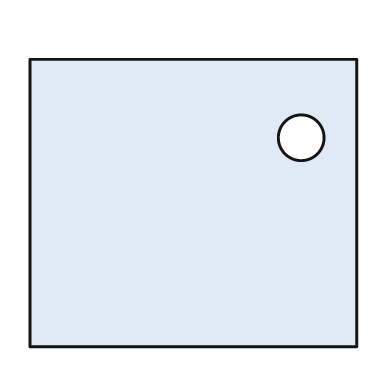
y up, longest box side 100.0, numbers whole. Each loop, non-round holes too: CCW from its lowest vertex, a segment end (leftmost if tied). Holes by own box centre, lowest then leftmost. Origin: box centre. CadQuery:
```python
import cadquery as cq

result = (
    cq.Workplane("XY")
    .moveTo(-50.0, -44.0)
    .lineTo(50.0, -44.0)
    .lineTo(50.0, 44.0)
    .lineTo(-50.0, 44.0)
    .close()
    .moveTo(33.0, 20.0)
    .circle(7.0)
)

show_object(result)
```